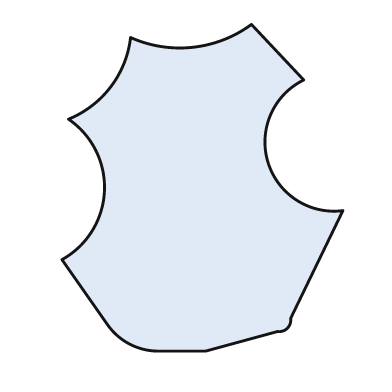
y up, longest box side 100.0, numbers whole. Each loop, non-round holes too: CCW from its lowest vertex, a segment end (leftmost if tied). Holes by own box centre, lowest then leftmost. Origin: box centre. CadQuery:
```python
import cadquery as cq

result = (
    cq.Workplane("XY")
    .moveTo(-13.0, -50.0)
    .lineTo(1.0, -50.0)
    .lineTo(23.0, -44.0)
    .threePointArc((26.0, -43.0), (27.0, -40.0))
    .lineTo(43.0, -7.0)
    .threePointArc((20.0, 8.0), (31.0, 33.0))
    .lineTo(15.0, 50.0)
    .threePointArc((-3.0, 43.0), (-22.0, 46.0))
    .threePointArc((-28.0, 31.0), (-41.0, 21.0))
    .threePointArc((-30.0, -1.0), (-43.0, -22.0))
    .lineTo(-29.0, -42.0)
    .threePointArc((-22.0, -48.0), (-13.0, -50.0))
    .close()
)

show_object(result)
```